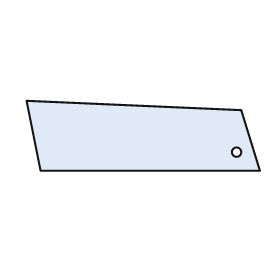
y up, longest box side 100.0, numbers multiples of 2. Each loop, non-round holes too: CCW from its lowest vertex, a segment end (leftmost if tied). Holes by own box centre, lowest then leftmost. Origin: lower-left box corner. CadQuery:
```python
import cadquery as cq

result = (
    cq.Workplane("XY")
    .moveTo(6.0, 0.0)
    .lineTo(100.0, 0.0)
    .lineTo(92.0, 26.0)
    .lineTo(0.0, 30.0)
    .close()
    .moveTo(90.0, 8.0)
    .circle(2.0)
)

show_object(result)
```